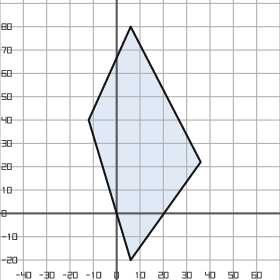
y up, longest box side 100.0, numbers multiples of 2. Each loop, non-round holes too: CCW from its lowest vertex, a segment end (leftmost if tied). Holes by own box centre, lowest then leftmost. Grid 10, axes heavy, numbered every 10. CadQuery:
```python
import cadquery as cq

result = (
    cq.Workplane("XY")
    .moveTo(6.0, -20.0)
    .lineTo(36.0, 22.0)
    .lineTo(6.0, 80.0)
    .lineTo(-12.0, 40.0)
    .close()
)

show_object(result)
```